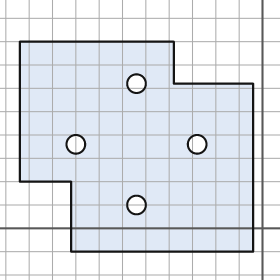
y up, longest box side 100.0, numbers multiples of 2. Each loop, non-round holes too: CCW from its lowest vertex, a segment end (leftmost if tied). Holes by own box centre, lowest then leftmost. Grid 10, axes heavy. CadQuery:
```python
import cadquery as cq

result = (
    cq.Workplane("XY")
    .moveTo(-82.0, -10.0)
    .lineTo(-4.0, -10.0)
    .lineTo(-4.0, 62.0)
    .lineTo(-38.0, 62.0)
    .lineTo(-38.0, 80.0)
    .lineTo(-104.0, 80.0)
    .lineTo(-104.0, 20.0)
    .lineTo(-82.0, 20.0)
    .close()
    .moveTo(-54.0, 10.0)
    .circle(4.0)
    .moveTo(-80.0, 36.0)
    .circle(4.0)
    .moveTo(-28.0, 36.0)
    .circle(4.0)
    .moveTo(-54.0, 62.0)
    .circle(4.0)
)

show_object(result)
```